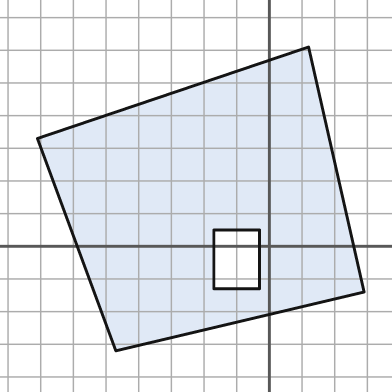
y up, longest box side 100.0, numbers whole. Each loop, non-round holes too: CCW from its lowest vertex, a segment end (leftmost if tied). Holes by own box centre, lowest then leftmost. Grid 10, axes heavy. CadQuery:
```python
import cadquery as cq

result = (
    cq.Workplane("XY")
    .moveTo(-47.0, -32.0)
    .lineTo(29.0, -14.0)
    .lineTo(12.0, 61.0)
    .lineTo(-71.0, 33.0)
    .close()
    .moveTo(-17.0, -13.0)
    .lineTo(-3.0, -13.0)
    .lineTo(-3.0, 5.0)
    .lineTo(-17.0, 5.0)
    .close()
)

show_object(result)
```